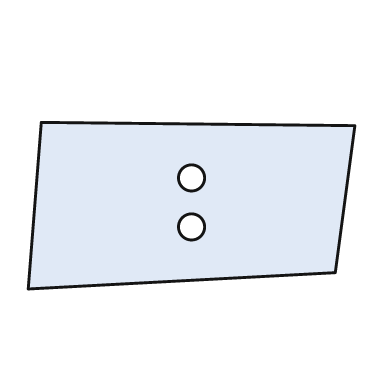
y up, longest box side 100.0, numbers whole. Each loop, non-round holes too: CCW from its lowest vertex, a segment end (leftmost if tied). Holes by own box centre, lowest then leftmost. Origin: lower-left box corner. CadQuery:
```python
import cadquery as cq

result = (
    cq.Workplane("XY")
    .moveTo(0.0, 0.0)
    .lineTo(94.0, 5.0)
    .lineTo(100.0, 50.0)
    .lineTo(4.0, 51.0)
    .close()
    .moveTo(50.0, 19.0)
    .circle(4.0)
    .moveTo(50.0, 34.0)
    .circle(4.0)
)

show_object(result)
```